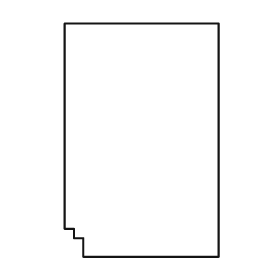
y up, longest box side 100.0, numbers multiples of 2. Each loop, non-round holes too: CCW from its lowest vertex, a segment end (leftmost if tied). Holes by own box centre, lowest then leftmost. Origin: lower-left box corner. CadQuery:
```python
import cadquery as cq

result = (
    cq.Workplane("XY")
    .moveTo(8.0, 0.0)
    .lineTo(66.0, 0.0)
    .lineTo(66.0, 100.0)
    .lineTo(0.0, 100.0)
    .lineTo(0.0, 12.0)
    .lineTo(4.0, 12.0)
    .lineTo(4.0, 8.0)
    .lineTo(8.0, 8.0)
    .close()
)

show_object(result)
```